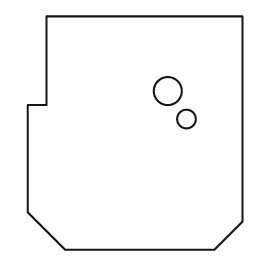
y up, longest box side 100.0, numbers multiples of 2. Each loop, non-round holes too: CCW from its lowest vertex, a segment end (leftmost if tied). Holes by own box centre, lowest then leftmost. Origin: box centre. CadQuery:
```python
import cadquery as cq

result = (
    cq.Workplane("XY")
    .moveTo(-30.0, -50.0)
    .lineTo(34.0, -50.0)
    .lineTo(46.0, -38.0)
    .lineTo(46.0, 50.0)
    .lineTo(-38.0, 50.0)
    .lineTo(-38.0, 12.0)
    .lineTo(-46.0, 12.0)
    .lineTo(-46.0, -34.0)
    .close()
    .moveTo(22.0, 6.0)
    .circle(4.0)
    .moveTo(14.0, 18.0)
    .circle(6.0)
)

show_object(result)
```